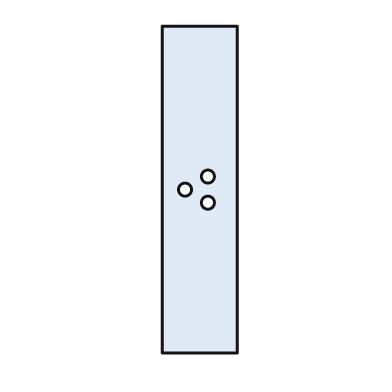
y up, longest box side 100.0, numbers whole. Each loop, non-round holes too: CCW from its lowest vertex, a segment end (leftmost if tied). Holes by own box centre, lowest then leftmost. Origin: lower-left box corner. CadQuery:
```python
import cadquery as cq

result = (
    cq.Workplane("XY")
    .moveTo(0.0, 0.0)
    .lineTo(23.0, 0.0)
    .lineTo(23.0, 100.0)
    .lineTo(0.0, 100.0)
    .close()
    .moveTo(14.0, 46.0)
    .circle(2.0)
    .moveTo(7.0, 50.0)
    .circle(2.0)
    .moveTo(14.0, 54.0)
    .circle(2.0)
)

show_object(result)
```